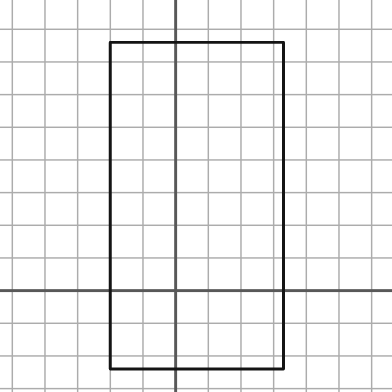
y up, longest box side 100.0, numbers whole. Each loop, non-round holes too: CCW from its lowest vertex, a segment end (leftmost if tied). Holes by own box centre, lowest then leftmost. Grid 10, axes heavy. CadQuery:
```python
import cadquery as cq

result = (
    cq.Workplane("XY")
    .moveTo(-20.0, -24.0)
    .lineTo(33.0, -24.0)
    .lineTo(33.0, 76.0)
    .lineTo(-20.0, 76.0)
    .close()
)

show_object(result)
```